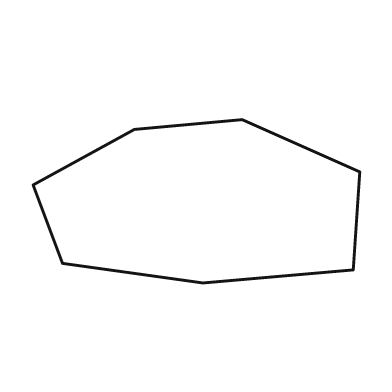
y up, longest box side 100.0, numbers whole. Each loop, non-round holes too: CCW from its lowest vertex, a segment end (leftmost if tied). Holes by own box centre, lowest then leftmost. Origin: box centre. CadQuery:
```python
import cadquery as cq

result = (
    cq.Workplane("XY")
    .moveTo(2.0, -25.0)
    .lineTo(48.0, -21.0)
    .lineTo(50.0, 9.0)
    .lineTo(14.0, 25.0)
    .lineTo(-19.0, 22.0)
    .lineTo(-50.0, 5.0)
    .lineTo(-41.0, -19.0)
    .close()
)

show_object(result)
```